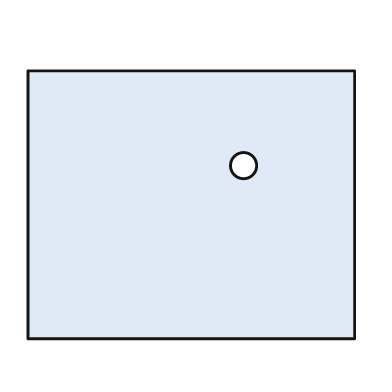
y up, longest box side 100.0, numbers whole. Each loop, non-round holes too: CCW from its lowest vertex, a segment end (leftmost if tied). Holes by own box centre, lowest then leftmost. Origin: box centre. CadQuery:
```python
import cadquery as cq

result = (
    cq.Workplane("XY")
    .moveTo(-50.0, -41.0)
    .lineTo(50.0, -41.0)
    .lineTo(50.0, 41.0)
    .lineTo(-50.0, 41.0)
    .close()
    .moveTo(16.0, 12.0)
    .circle(4.0)
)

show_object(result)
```